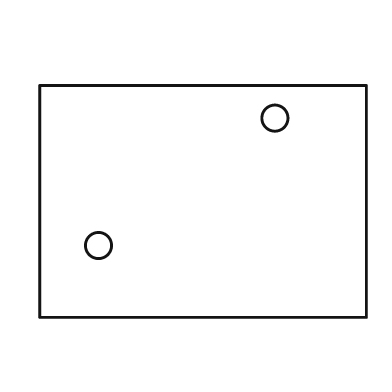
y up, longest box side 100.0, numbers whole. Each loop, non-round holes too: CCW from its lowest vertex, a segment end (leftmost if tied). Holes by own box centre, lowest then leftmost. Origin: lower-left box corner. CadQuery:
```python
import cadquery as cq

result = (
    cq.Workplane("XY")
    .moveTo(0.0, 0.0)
    .lineTo(100.0, 0.0)
    .lineTo(100.0, 71.0)
    .lineTo(0.0, 71.0)
    .close()
    .moveTo(18.0, 22.0)
    .circle(4.0)
    .moveTo(72.0, 61.0)
    .circle(4.0)
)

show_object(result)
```